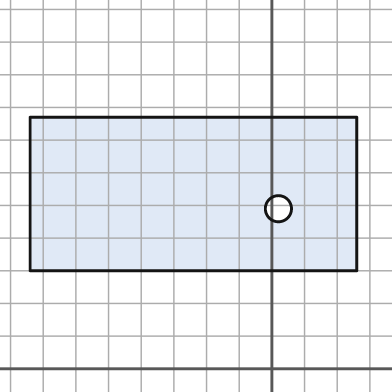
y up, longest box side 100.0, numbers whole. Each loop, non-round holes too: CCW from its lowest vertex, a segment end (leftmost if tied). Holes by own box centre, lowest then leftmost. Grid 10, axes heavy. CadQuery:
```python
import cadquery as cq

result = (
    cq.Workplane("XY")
    .moveTo(-74.0, 30.0)
    .lineTo(26.0, 30.0)
    .lineTo(26.0, 77.0)
    .lineTo(-74.0, 77.0)
    .close()
    .moveTo(2.0, 49.0)
    .circle(4.0)
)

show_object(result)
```